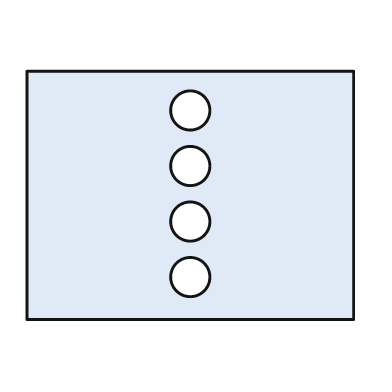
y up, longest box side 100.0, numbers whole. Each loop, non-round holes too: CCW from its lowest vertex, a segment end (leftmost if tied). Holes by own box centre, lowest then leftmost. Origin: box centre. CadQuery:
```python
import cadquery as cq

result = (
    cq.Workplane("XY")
    .moveTo(-50.0, -38.0)
    .lineTo(50.0, -38.0)
    .lineTo(50.0, 38.0)
    .lineTo(-50.0, 38.0)
    .close()
    .moveTo(0.0, -25.0)
    .circle(6.0)
    .moveTo(0.0, -8.0)
    .circle(6.0)
    .moveTo(0.0, 9.0)
    .circle(6.0)
    .moveTo(0.0, 26.0)
    .circle(6.0)
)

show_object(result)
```